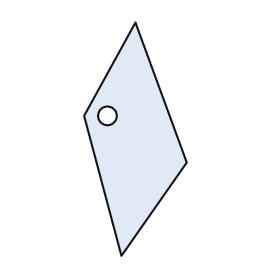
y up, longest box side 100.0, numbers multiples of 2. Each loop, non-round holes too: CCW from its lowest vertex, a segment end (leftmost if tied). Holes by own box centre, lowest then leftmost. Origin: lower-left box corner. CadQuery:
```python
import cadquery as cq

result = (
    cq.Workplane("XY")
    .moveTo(16.0, 0.0)
    .lineTo(44.0, 40.0)
    .lineTo(22.0, 100.0)
    .lineTo(0.0, 60.0)
    .close()
    .moveTo(10.0, 60.0)
    .circle(4.0)
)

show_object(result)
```